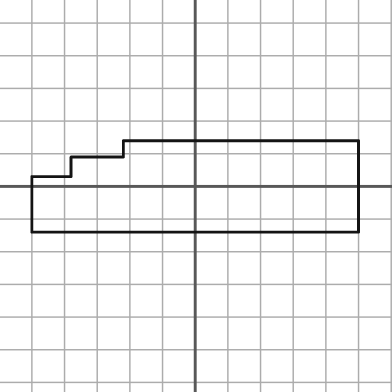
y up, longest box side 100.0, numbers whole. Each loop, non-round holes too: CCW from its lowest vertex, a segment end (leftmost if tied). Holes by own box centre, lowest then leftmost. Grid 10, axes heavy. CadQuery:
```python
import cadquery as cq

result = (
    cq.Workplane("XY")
    .moveTo(-50.0, -14.0)
    .lineTo(50.0, -14.0)
    .lineTo(50.0, 14.0)
    .lineTo(-22.0, 14.0)
    .lineTo(-22.0, 9.0)
    .lineTo(-38.0, 9.0)
    .lineTo(-38.0, 3.0)
    .lineTo(-50.0, 3.0)
    .close()
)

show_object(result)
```